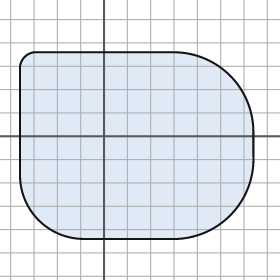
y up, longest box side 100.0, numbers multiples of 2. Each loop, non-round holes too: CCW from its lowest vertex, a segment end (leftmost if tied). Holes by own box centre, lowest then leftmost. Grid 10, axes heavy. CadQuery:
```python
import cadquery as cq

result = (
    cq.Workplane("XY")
    .moveTo(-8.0, -44.0)
    .lineTo(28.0, -44.0)
    .threePointArc((54.0, -34.0), (64.0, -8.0))
    .lineTo(64.0, 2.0)
    .threePointArc((54.0, 26.0), (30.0, 36.0))
    .lineTo(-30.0, 36.0)
    .threePointArc((-34.0, 34.0), (-36.0, 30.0))
    .lineTo(-36.0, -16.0)
    .threePointArc((-28.0, -36.0), (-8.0, -44.0))
    .close()
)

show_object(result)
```